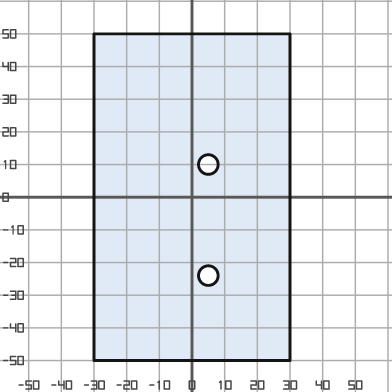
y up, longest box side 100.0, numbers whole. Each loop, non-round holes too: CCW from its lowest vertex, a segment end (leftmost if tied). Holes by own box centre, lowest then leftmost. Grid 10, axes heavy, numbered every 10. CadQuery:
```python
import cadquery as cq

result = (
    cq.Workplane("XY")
    .moveTo(-30.0, -50.0)
    .lineTo(30.0, -50.0)
    .lineTo(30.0, 50.0)
    .lineTo(-30.0, 50.0)
    .close()
    .moveTo(5.0, -24.0)
    .circle(3.0)
    .moveTo(5.0, 10.0)
    .circle(3.0)
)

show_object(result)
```